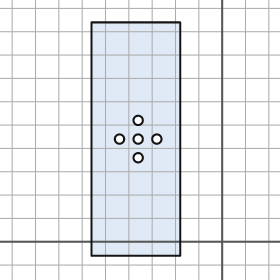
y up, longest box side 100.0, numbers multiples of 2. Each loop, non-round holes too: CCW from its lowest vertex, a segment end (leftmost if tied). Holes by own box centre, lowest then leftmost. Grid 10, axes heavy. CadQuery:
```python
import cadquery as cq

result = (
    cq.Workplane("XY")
    .moveTo(-56.0, -6.0)
    .lineTo(-18.0, -6.0)
    .lineTo(-18.0, 94.0)
    .lineTo(-56.0, 94.0)
    .close()
    .moveTo(-36.0, 36.0)
    .circle(2.0)
    .moveTo(-44.0, 44.0)
    .circle(2.0)
    .moveTo(-36.0, 44.0)
    .circle(2.0)
    .moveTo(-28.0, 44.0)
    .circle(2.0)
    .moveTo(-36.0, 52.0)
    .circle(2.0)
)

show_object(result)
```